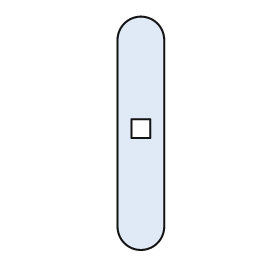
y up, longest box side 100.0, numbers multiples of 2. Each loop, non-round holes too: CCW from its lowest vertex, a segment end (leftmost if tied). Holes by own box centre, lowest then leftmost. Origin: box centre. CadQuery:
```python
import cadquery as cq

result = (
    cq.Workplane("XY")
    .moveTo(-10.0, -40.0)
    .threePointArc((0.0, -50.0), (10.0, -40.0))
    .lineTo(10.0, 40.0)
    .threePointArc((0.0, 50.0), (-10.0, 40.0))
    .close()
    .moveTo(-4.0, -2.0)
    .lineTo(4.0, -2.0)
    .lineTo(4.0, 6.0)
    .lineTo(-4.0, 6.0)
    .close()
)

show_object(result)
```